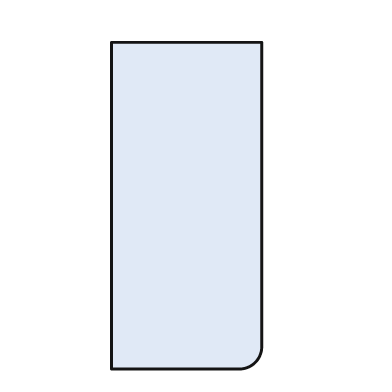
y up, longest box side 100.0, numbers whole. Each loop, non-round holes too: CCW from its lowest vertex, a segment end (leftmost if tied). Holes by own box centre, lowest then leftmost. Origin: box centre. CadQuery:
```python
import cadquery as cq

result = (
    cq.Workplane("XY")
    .moveTo(-23.0, -50.0)
    .lineTo(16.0, -50.0)
    .threePointArc((21.0, -48.0), (23.0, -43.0))
    .lineTo(23.0, 50.0)
    .lineTo(-23.0, 50.0)
    .close()
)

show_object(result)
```